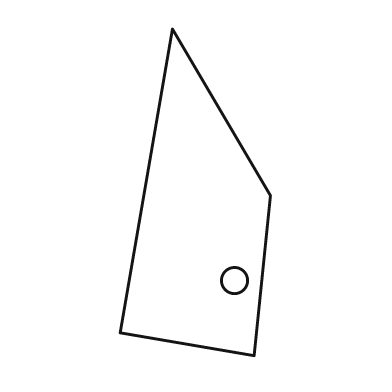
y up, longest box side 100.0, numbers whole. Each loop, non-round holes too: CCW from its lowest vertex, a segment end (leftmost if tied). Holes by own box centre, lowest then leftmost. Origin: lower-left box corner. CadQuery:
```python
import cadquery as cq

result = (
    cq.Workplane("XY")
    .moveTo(41.0, 0.0)
    .lineTo(46.0, 49.0)
    .lineTo(16.0, 100.0)
    .lineTo(0.0, 7.0)
    .close()
    .moveTo(35.0, 23.0)
    .circle(4.0)
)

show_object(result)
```